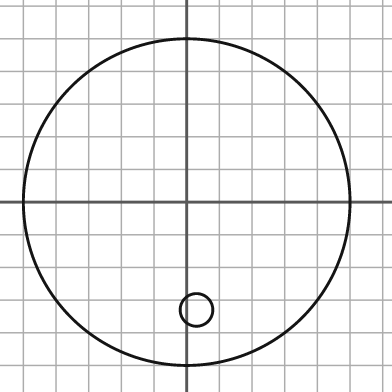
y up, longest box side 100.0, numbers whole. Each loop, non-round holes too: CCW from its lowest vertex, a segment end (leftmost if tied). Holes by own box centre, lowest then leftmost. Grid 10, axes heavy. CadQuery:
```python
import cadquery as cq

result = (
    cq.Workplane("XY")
    .moveTo(0.0, 0.0)
    .circle(50.0)
    .moveTo(3.0, -33.0)
    .circle(5.0)
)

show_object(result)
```